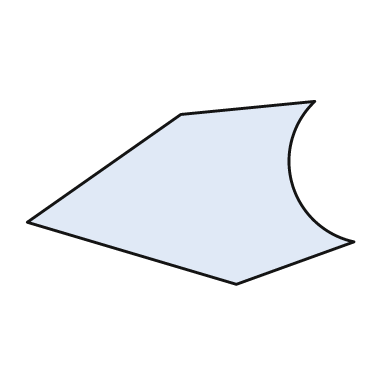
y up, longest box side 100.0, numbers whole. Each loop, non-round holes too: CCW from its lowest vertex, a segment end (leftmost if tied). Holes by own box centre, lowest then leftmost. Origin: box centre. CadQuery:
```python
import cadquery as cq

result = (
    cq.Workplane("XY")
    .moveTo(14.0, -28.0)
    .lineTo(50.0, -15.0)
    .threePointArc((31.0, 3.0), (38.0, 28.0))
    .lineTo(-3.0, 24.0)
    .lineTo(-50.0, -9.0)
    .close()
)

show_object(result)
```